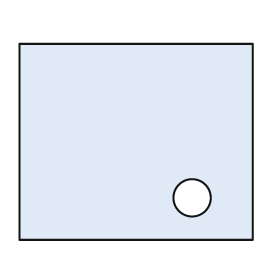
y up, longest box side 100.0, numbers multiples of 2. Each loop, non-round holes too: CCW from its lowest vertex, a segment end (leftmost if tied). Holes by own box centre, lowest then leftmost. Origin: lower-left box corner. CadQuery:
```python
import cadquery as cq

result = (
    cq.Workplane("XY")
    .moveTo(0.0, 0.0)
    .lineTo(100.0, 0.0)
    .lineTo(100.0, 84.0)
    .lineTo(0.0, 84.0)
    .close()
    .moveTo(74.0, 18.0)
    .circle(8.0)
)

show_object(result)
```